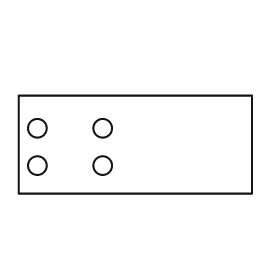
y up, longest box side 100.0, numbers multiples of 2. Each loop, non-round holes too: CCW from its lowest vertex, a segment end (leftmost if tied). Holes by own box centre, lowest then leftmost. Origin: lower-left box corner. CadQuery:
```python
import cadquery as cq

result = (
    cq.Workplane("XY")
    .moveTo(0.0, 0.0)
    .lineTo(100.0, 0.0)
    .lineTo(100.0, 42.0)
    .lineTo(0.0, 42.0)
    .close()
    .moveTo(8.0, 12.0)
    .circle(4.0)
    .moveTo(36.0, 12.0)
    .circle(4.0)
    .moveTo(8.0, 28.0)
    .circle(4.0)
    .moveTo(36.0, 28.0)
    .circle(4.0)
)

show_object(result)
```